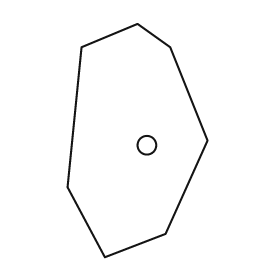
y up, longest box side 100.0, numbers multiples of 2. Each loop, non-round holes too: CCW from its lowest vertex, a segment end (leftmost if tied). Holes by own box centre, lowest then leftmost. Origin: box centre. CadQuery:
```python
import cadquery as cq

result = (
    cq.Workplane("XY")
    .moveTo(-14.0, -50.0)
    .lineTo(12.0, -40.0)
    .lineTo(30.0, 0.0)
    .lineTo(14.0, 40.0)
    .lineTo(0.0, 50.0)
    .lineTo(-24.0, 40.0)
    .lineTo(-30.0, -20.0)
    .close()
    .moveTo(4.0, -2.0)
    .circle(4.0)
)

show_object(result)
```